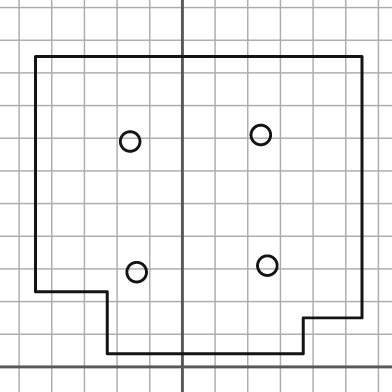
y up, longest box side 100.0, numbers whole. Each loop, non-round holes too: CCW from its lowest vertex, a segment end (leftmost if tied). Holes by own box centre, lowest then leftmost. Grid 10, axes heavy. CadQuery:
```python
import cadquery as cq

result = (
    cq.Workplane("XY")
    .moveTo(-23.0, 4.0)
    .lineTo(37.0, 4.0)
    .lineTo(37.0, 15.0)
    .lineTo(55.0, 15.0)
    .lineTo(55.0, 95.0)
    .lineTo(-45.0, 95.0)
    .lineTo(-45.0, 23.0)
    .lineTo(-23.0, 23.0)
    .close()
    .moveTo(-14.0, 29.0)
    .circle(3.0)
    .moveTo(26.0, 31.0)
    .circle(3.0)
    .moveTo(-16.0, 69.0)
    .circle(3.0)
    .moveTo(24.0, 71.0)
    .circle(3.0)
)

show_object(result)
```